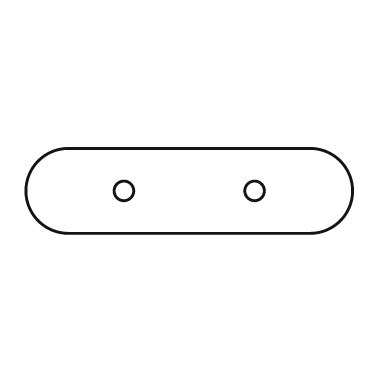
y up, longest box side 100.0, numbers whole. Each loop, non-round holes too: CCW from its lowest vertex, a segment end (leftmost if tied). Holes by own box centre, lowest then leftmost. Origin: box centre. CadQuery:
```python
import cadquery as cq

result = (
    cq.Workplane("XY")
    .moveTo(-37.0, -13.0)
    .lineTo(37.0, -13.0)
    .threePointArc((50.0, 0.0), (37.0, 13.0))
    .lineTo(-37.0, 13.0)
    .threePointArc((-50.0, 0.0), (-37.0, -13.0))
    .close()
    .moveTo(-20.0, 0.0)
    .circle(3.0)
    .moveTo(20.0, 0.0)
    .circle(3.0)
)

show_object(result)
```